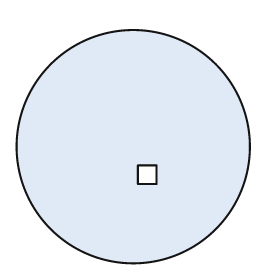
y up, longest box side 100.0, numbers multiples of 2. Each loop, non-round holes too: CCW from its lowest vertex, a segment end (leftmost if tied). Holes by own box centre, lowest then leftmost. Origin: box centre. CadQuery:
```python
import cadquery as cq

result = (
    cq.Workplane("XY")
    .moveTo(0.0, 0.0)
    .circle(50.0)
    .moveTo(2.0, -16.0)
    .lineTo(10.0, -16.0)
    .lineTo(10.0, -8.0)
    .lineTo(2.0, -8.0)
    .close()
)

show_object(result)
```